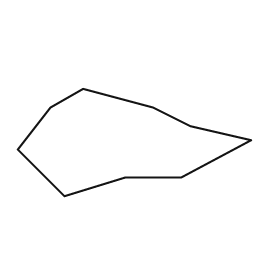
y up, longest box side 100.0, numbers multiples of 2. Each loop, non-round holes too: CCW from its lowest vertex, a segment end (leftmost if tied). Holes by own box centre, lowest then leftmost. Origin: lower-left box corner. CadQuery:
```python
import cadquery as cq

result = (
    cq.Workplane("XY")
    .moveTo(20.0, 0.0)
    .lineTo(46.0, 8.0)
    .lineTo(70.0, 8.0)
    .lineTo(100.0, 24.0)
    .lineTo(74.0, 30.0)
    .lineTo(58.0, 38.0)
    .lineTo(28.0, 46.0)
    .lineTo(14.0, 38.0)
    .lineTo(0.0, 20.0)
    .close()
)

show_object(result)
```